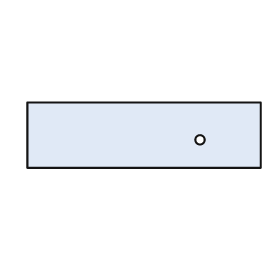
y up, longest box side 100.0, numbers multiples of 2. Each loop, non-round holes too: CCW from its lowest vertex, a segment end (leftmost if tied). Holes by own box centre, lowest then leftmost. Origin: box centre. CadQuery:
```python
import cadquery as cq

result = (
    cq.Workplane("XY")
    .moveTo(-50.0, -14.0)
    .lineTo(50.0, -14.0)
    .lineTo(50.0, 14.0)
    .lineTo(-50.0, 14.0)
    .close()
    .moveTo(24.0, -2.0)
    .circle(2.0)
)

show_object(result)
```